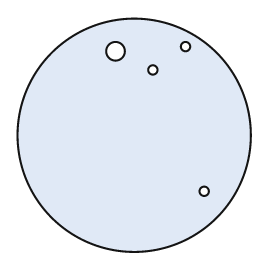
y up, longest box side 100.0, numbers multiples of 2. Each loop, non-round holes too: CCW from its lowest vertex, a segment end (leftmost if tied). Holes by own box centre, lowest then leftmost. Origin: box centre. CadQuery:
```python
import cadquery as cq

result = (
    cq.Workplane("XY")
    .moveTo(0.0, 0.0)
    .circle(50.0)
    .moveTo(30.0, -24.0)
    .circle(2.0)
    .moveTo(8.0, 28.0)
    .circle(2.0)
    .moveTo(-8.0, 36.0)
    .circle(4.0)
    .moveTo(22.0, 38.0)
    .circle(2.0)
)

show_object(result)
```